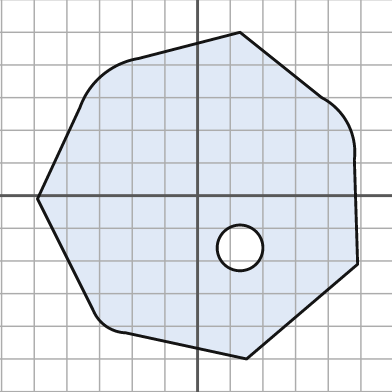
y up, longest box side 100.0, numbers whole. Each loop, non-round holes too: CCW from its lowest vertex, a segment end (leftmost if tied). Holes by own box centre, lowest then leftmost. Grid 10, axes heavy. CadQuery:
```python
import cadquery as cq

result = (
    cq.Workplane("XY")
    .moveTo(15.0, -50.0)
    .lineTo(49.0, -21.0)
    .lineTo(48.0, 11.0)
    .threePointArc((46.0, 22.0), (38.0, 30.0))
    .lineTo(13.0, 50.0)
    .lineTo(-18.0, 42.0)
    .threePointArc((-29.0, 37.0), (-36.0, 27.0))
    .lineTo(-49.0, -1.0)
    .lineTo(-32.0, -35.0)
    .threePointArc((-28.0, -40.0), (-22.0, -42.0))
    .close()
    .moveTo(13.0, -16.0)
    .circle(7.0)
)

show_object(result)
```